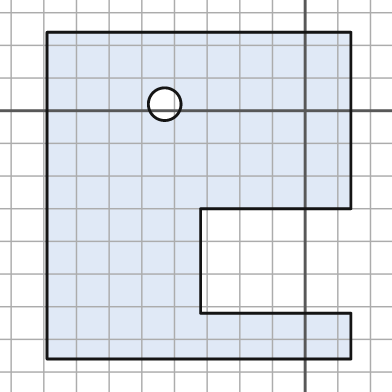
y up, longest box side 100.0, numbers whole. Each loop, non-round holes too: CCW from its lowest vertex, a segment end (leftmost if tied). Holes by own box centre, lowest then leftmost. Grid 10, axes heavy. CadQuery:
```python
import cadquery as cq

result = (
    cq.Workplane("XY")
    .moveTo(-79.0, -76.0)
    .lineTo(14.0, -76.0)
    .lineTo(14.0, -62.0)
    .lineTo(-32.0, -62.0)
    .lineTo(-32.0, -30.0)
    .lineTo(14.0, -30.0)
    .lineTo(14.0, 24.0)
    .lineTo(-79.0, 24.0)
    .close()
    .moveTo(-43.0, 2.0)
    .circle(5.0)
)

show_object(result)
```